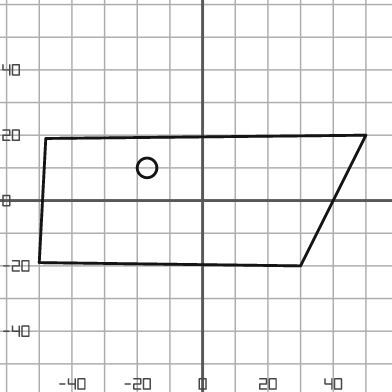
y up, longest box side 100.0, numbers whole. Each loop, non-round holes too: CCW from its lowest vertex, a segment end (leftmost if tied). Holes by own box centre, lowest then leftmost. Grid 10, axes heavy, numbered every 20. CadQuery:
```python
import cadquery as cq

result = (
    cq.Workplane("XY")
    .moveTo(30.0, -20.0)
    .lineTo(50.0, 20.0)
    .lineTo(-48.0, 19.0)
    .lineTo(-50.0, -19.0)
    .close()
    .moveTo(-17.0, 10.0)
    .circle(3.0)
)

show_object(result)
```